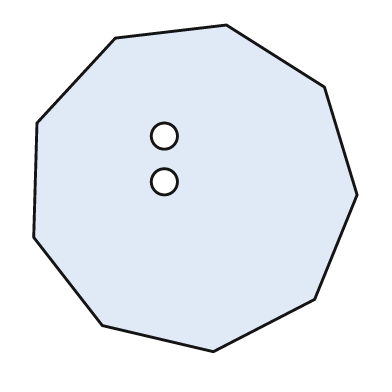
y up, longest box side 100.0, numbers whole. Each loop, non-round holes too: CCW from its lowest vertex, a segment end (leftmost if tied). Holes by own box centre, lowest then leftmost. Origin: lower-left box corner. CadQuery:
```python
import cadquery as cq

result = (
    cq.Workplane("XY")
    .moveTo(55.0, 0.0)
    .lineTo(86.0, 16.0)
    .lineTo(99.0, 48.0)
    .lineTo(89.0, 81.0)
    .lineTo(59.0, 100.0)
    .lineTo(25.0, 96.0)
    .lineTo(1.0, 70.0)
    .lineTo(0.0, 35.0)
    .lineTo(21.0, 8.0)
    .close()
    .moveTo(40.0, 52.0)
    .circle(4.0)
    .moveTo(40.0, 66.0)
    .circle(4.0)
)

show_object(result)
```